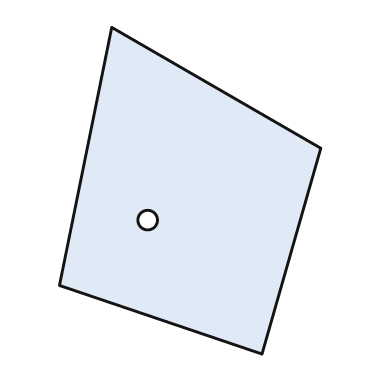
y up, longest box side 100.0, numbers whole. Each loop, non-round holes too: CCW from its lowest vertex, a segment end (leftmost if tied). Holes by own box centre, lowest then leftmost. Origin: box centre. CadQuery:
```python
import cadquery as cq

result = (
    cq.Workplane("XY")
    .moveTo(22.0, -50.0)
    .lineTo(40.0, 13.0)
    .lineTo(-24.0, 50.0)
    .lineTo(-40.0, -29.0)
    .close()
    .moveTo(-13.0, -9.0)
    .circle(3.0)
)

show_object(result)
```